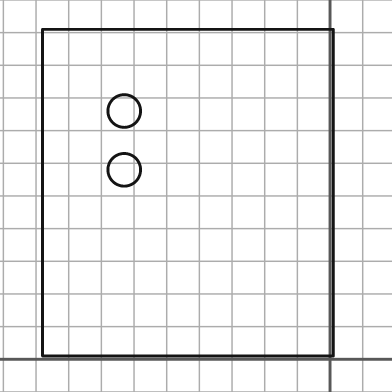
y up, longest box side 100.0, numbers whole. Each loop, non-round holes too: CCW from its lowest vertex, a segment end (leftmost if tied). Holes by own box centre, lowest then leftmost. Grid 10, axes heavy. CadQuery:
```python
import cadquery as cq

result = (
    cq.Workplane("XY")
    .moveTo(-88.0, 1.0)
    .lineTo(1.0, 1.0)
    .lineTo(1.0, 101.0)
    .lineTo(-88.0, 101.0)
    .close()
    .moveTo(-63.0, 58.0)
    .circle(5.0)
    .moveTo(-63.0, 76.0)
    .circle(5.0)
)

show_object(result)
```